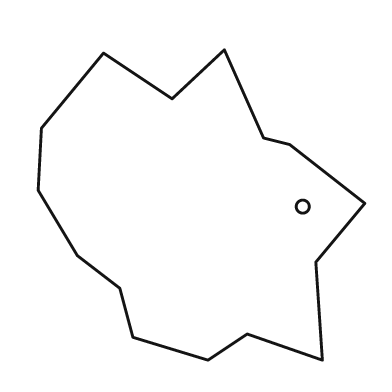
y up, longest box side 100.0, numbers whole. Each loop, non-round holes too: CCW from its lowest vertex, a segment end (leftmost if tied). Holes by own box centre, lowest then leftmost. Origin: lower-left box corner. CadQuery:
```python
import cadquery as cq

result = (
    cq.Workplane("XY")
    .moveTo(52.0, 0.0)
    .lineTo(64.0, 8.0)
    .lineTo(87.0, 0.0)
    .lineTo(85.0, 30.0)
    .lineTo(100.0, 48.0)
    .lineTo(77.0, 66.0)
    .lineTo(69.0, 68.0)
    .lineTo(57.0, 95.0)
    .lineTo(41.0, 80.0)
    .lineTo(20.0, 94.0)
    .lineTo(1.0, 71.0)
    .lineTo(0.0, 52.0)
    .lineTo(12.0, 32.0)
    .lineTo(25.0, 22.0)
    .lineTo(29.0, 7.0)
    .close()
    .moveTo(81.0, 47.0)
    .circle(2.0)
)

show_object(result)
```